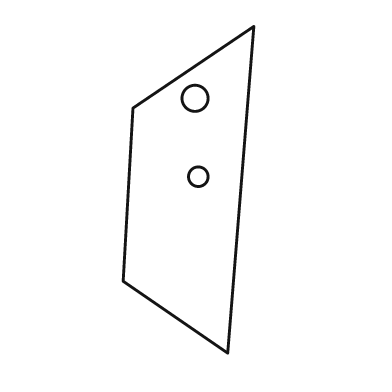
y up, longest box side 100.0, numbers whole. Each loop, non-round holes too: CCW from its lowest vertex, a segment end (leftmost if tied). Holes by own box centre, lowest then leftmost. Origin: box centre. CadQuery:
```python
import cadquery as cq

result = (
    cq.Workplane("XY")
    .moveTo(12.0, -50.0)
    .lineTo(20.0, 50.0)
    .lineTo(-17.0, 25.0)
    .lineTo(-20.0, -28.0)
    .close()
    .moveTo(3.0, 4.0)
    .circle(3.0)
    .moveTo(2.0, 28.0)
    .circle(4.0)
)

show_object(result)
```